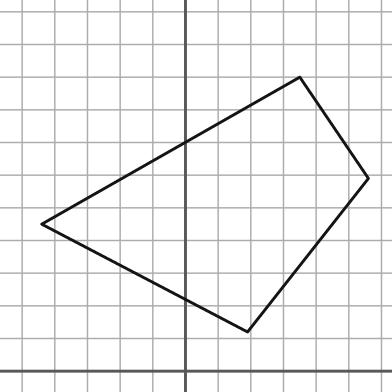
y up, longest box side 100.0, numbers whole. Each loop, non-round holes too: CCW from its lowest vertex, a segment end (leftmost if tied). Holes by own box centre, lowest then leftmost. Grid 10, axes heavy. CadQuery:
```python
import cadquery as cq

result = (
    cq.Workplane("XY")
    .moveTo(19.0, 12.0)
    .lineTo(56.0, 59.0)
    .lineTo(35.0, 90.0)
    .lineTo(-44.0, 45.0)
    .close()
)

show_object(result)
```